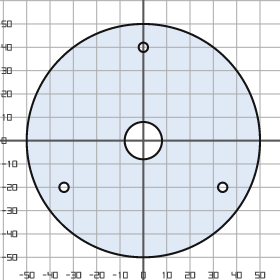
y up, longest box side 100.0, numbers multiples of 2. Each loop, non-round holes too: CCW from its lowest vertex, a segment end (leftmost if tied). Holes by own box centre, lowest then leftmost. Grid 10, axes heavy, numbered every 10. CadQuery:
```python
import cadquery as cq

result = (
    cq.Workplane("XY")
    .moveTo(0.0, 0.0)
    .circle(50.0)
    .moveTo(-34.0, -20.0)
    .circle(2.0)
    .moveTo(34.0, -20.0)
    .circle(2.0)
    .moveTo(0.0, 0.0)
    .circle(8.0)
    .moveTo(0.0, 40.0)
    .circle(2.0)
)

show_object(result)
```